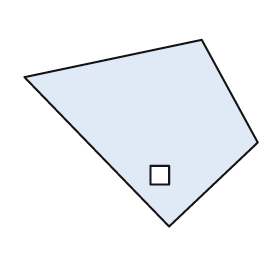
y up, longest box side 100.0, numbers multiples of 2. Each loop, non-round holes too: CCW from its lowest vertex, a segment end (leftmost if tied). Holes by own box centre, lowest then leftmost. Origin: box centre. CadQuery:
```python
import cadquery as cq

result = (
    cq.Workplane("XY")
    .moveTo(12.0, -40.0)
    .lineTo(50.0, -4.0)
    .lineTo(26.0, 40.0)
    .lineTo(-50.0, 24.0)
    .close()
    .moveTo(4.0, -22.0)
    .lineTo(12.0, -22.0)
    .lineTo(12.0, -14.0)
    .lineTo(4.0, -14.0)
    .close()
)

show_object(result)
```